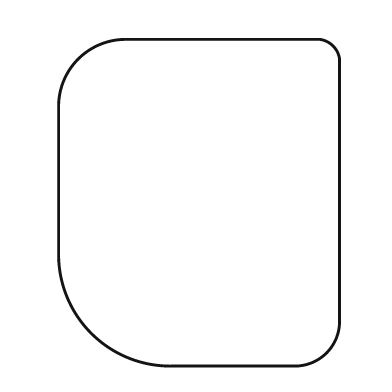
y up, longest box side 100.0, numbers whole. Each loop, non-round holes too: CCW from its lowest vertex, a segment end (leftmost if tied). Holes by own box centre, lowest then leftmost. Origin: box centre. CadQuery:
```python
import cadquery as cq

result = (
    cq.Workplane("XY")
    .moveTo(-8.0, -50.0)
    .lineTo(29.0, -50.0)
    .threePointArc((39.0, -46.0), (43.0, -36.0))
    .lineTo(43.0, 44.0)
    .threePointArc((41.0, 48.0), (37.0, 50.0))
    .lineTo(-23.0, 50.0)
    .threePointArc((-37.0, 44.0), (-43.0, 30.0))
    .lineTo(-43.0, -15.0)
    .threePointArc((-33.0, -40.0), (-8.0, -50.0))
    .close()
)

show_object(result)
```